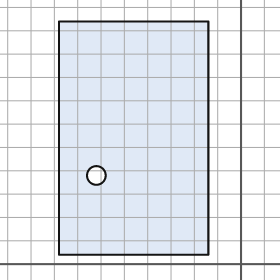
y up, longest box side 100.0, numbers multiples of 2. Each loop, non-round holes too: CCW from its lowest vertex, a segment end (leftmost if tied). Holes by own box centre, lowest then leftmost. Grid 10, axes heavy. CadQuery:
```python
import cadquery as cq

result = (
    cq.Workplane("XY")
    .moveTo(-78.0, 4.0)
    .lineTo(-14.0, 4.0)
    .lineTo(-14.0, 104.0)
    .lineTo(-78.0, 104.0)
    .close()
    .moveTo(-62.0, 38.0)
    .circle(4.0)
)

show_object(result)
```